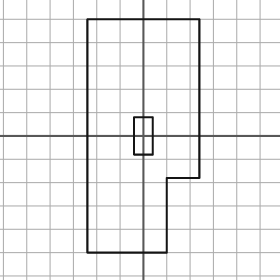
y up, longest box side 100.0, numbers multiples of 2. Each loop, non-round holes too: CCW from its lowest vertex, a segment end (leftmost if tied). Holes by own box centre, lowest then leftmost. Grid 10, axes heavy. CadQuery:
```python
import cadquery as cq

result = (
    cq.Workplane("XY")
    .moveTo(-24.0, -50.0)
    .lineTo(10.0, -50.0)
    .lineTo(10.0, -18.0)
    .lineTo(24.0, -18.0)
    .lineTo(24.0, 50.0)
    .lineTo(-24.0, 50.0)
    .close()
    .moveTo(-4.0, -8.0)
    .lineTo(4.0, -8.0)
    .lineTo(4.0, 8.0)
    .lineTo(-4.0, 8.0)
    .close()
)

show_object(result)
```